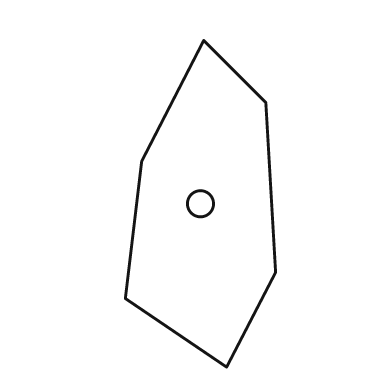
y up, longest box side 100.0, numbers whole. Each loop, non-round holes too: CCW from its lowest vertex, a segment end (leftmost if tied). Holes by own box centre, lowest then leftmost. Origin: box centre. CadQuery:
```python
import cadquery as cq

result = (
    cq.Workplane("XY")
    .moveTo(8.0, -50.0)
    .lineTo(23.0, -21.0)
    .lineTo(20.0, 31.0)
    .lineTo(1.0, 50.0)
    .lineTo(-18.0, 13.0)
    .lineTo(-23.0, -29.0)
    .close()
    .moveTo(0.0, 0.0)
    .circle(4.0)
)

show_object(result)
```